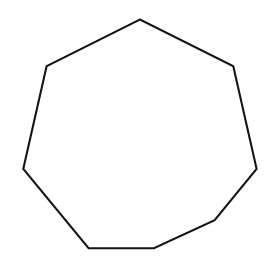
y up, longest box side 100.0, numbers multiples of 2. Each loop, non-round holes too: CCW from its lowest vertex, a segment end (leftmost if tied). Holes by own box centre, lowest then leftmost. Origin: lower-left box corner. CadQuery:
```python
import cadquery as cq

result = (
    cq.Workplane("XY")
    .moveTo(28.0, 0.0)
    .lineTo(56.0, 0.0)
    .lineTo(82.0, 12.0)
    .lineTo(100.0, 34.0)
    .lineTo(90.0, 78.0)
    .lineTo(50.0, 98.0)
    .lineTo(10.0, 78.0)
    .lineTo(0.0, 34.0)
    .close()
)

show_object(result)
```